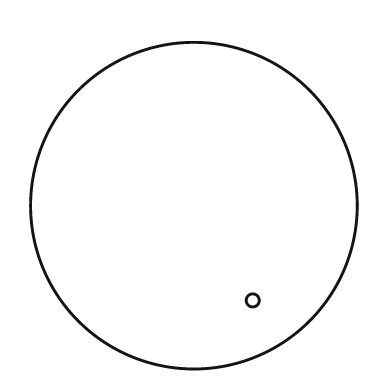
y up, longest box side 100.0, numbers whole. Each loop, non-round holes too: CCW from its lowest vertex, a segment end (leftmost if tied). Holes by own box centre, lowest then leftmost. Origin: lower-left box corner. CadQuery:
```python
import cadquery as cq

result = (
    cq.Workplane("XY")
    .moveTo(50.0, 50.0)
    .circle(50.0)
    .moveTo(68.0, 21.0)
    .circle(2.0)
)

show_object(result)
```